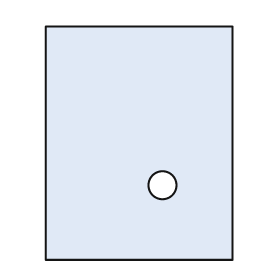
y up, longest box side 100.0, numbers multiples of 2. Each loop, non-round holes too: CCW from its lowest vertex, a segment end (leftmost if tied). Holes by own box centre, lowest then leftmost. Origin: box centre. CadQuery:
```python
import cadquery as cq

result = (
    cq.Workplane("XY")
    .moveTo(-40.0, -50.0)
    .lineTo(40.0, -50.0)
    .lineTo(40.0, 50.0)
    .lineTo(-40.0, 50.0)
    .close()
    .moveTo(10.0, -18.0)
    .circle(6.0)
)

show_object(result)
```